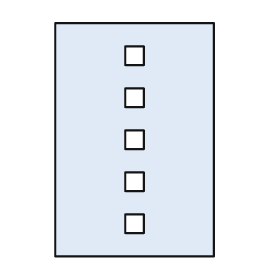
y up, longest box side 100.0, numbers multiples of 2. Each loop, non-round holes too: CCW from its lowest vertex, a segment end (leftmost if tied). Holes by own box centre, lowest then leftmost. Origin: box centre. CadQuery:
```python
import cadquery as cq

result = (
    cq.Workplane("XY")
    .moveTo(-34.0, -50.0)
    .lineTo(34.0, -50.0)
    .lineTo(34.0, 50.0)
    .lineTo(-34.0, 50.0)
    .close()
    .moveTo(-4.0, -40.0)
    .lineTo(4.0, -40.0)
    .lineTo(4.0, -32.0)
    .lineTo(-4.0, -32.0)
    .close()
    .moveTo(-4.0, -22.0)
    .lineTo(4.0, -22.0)
    .lineTo(4.0, -14.0)
    .lineTo(-4.0, -14.0)
    .close()
    .moveTo(-4.0, -4.0)
    .lineTo(4.0, -4.0)
    .lineTo(4.0, 4.0)
    .lineTo(-4.0, 4.0)
    .close()
    .moveTo(-4.0, 14.0)
    .lineTo(4.0, 14.0)
    .lineTo(4.0, 22.0)
    .lineTo(-4.0, 22.0)
    .close()
    .moveTo(-4.0, 32.0)
    .lineTo(4.0, 32.0)
    .lineTo(4.0, 40.0)
    .lineTo(-4.0, 40.0)
    .close()
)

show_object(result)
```